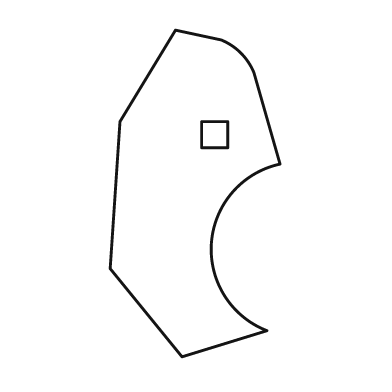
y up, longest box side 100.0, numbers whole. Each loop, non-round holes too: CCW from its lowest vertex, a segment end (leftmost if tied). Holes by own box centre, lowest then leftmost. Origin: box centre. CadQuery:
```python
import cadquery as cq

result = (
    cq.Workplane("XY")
    .moveTo(-4.0, -50.0)
    .lineTo(22.0, -42.0)
    .threePointArc((5.0, -15.0), (26.0, 9.0))
    .lineTo(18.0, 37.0)
    .threePointArc((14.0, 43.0), (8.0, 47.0))
    .lineTo(-6.0, 50.0)
    .lineTo(-23.0, 22.0)
    .lineTo(-26.0, -23.0)
    .close()
    .moveTo(2.0, 14.0)
    .lineTo(10.0, 14.0)
    .lineTo(10.0, 22.0)
    .lineTo(2.0, 22.0)
    .close()
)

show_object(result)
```